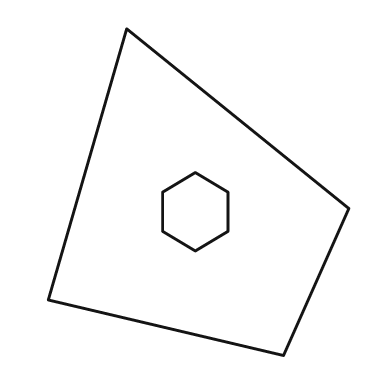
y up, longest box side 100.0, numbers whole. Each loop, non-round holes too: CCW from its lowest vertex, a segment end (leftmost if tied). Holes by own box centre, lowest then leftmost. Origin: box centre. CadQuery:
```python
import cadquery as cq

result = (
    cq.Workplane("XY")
    .moveTo(26.0, -50.0)
    .lineTo(46.0, -5.0)
    .lineTo(-22.0, 50.0)
    .lineTo(-46.0, -33.0)
    .close()
    .moveTo(-1.0, -18.0)
    .lineTo(9.0, -12.0)
    .lineTo(9.0, 0.0)
    .lineTo(-1.0, 6.0)
    .lineTo(-11.0, 0.0)
    .lineTo(-11.0, -12.0)
    .close()
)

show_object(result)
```